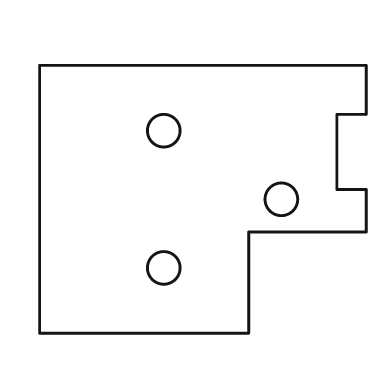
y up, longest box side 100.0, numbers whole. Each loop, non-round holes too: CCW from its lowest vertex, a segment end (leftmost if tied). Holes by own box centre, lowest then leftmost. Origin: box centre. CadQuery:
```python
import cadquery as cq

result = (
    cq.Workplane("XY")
    .moveTo(-50.0, -41.0)
    .lineTo(14.0, -41.0)
    .lineTo(14.0, -10.0)
    .lineTo(50.0, -10.0)
    .lineTo(50.0, 3.0)
    .lineTo(41.0, 3.0)
    .lineTo(41.0, 26.0)
    .lineTo(50.0, 26.0)
    .lineTo(50.0, 41.0)
    .lineTo(-50.0, 41.0)
    .close()
    .moveTo(-12.0, -21.0)
    .circle(5.0)
    .moveTo(24.0, 0.0)
    .circle(5.0)
    .moveTo(-12.0, 21.0)
    .circle(5.0)
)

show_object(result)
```